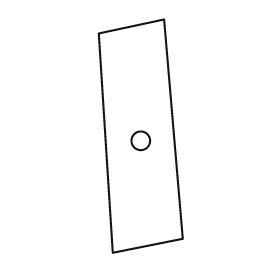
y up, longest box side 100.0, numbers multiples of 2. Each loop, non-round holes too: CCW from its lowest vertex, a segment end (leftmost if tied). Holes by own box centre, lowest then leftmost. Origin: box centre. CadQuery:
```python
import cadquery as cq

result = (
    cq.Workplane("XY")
    .moveTo(-12.0, -50.0)
    .lineTo(18.0, -44.0)
    .lineTo(10.0, 50.0)
    .lineTo(-18.0, 44.0)
    .close()
    .moveTo(0.0, -2.0)
    .circle(4.0)
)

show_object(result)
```